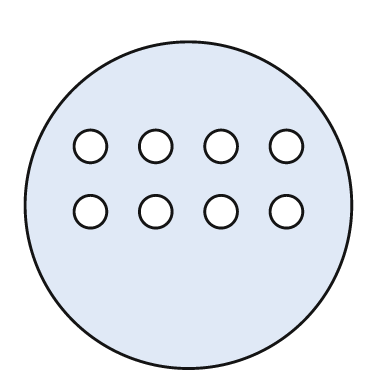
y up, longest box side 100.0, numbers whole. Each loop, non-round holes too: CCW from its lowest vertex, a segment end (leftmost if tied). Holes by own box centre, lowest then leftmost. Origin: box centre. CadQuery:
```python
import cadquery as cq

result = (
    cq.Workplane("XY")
    .moveTo(0.0, 0.0)
    .circle(50.0)
    .moveTo(-30.0, -2.0)
    .circle(5.0)
    .moveTo(-10.0, -2.0)
    .circle(5.0)
    .moveTo(10.0, -2.0)
    .circle(5.0)
    .moveTo(30.0, -2.0)
    .circle(5.0)
    .moveTo(-30.0, 18.0)
    .circle(5.0)
    .moveTo(-10.0, 18.0)
    .circle(5.0)
    .moveTo(10.0, 18.0)
    .circle(5.0)
    .moveTo(30.0, 18.0)
    .circle(5.0)
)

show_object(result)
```